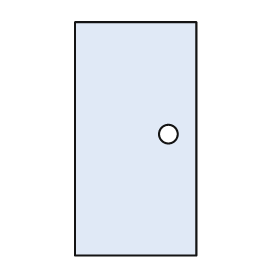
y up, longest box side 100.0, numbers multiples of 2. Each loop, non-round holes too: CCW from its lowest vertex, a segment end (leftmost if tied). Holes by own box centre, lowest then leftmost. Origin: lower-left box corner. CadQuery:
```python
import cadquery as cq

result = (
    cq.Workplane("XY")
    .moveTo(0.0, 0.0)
    .lineTo(52.0, 0.0)
    .lineTo(52.0, 100.0)
    .lineTo(0.0, 100.0)
    .close()
    .moveTo(40.0, 52.0)
    .circle(4.0)
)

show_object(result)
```